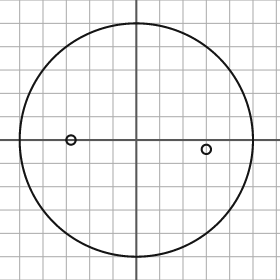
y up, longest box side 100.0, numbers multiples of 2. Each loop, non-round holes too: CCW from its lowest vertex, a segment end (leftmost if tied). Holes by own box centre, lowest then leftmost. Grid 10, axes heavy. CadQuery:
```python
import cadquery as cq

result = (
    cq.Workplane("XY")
    .moveTo(0.0, 0.0)
    .circle(50.0)
    .moveTo(30.0, -4.0)
    .circle(2.0)
    .moveTo(-28.0, 0.0)
    .circle(2.0)
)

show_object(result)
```